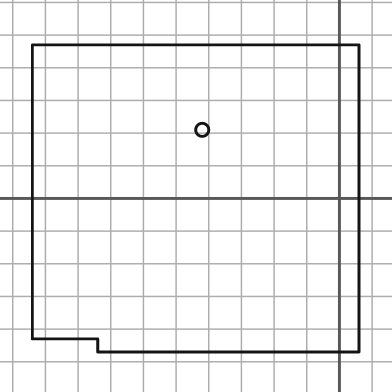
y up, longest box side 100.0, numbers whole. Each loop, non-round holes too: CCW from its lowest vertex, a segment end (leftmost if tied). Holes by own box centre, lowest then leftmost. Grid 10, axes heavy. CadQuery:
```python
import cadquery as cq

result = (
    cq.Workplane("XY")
    .moveTo(-74.0, -47.0)
    .lineTo(6.0, -47.0)
    .lineTo(6.0, 47.0)
    .lineTo(-94.0, 47.0)
    .lineTo(-94.0, -43.0)
    .lineTo(-74.0, -43.0)
    .close()
    .moveTo(-42.0, 21.0)
    .circle(2.0)
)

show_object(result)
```